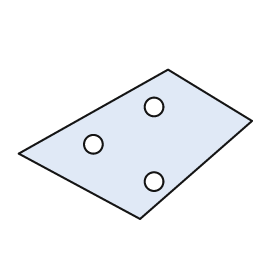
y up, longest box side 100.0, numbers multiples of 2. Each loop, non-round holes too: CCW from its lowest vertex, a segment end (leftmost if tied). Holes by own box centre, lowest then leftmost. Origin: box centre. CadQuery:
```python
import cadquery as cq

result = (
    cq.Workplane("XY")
    .moveTo(2.0, -32.0)
    .lineTo(50.0, 10.0)
    .lineTo(14.0, 32.0)
    .lineTo(-50.0, -4.0)
    .close()
    .moveTo(8.0, -16.0)
    .circle(4.0)
    .moveTo(-18.0, 0.0)
    .circle(4.0)
    .moveTo(8.0, 16.0)
    .circle(4.0)
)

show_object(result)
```